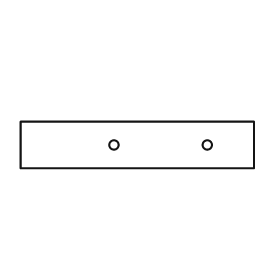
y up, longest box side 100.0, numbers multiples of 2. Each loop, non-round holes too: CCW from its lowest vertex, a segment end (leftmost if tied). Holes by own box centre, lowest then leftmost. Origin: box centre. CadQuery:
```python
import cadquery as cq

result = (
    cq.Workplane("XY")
    .moveTo(-50.0, -10.0)
    .lineTo(50.0, -10.0)
    .lineTo(50.0, 10.0)
    .lineTo(-50.0, 10.0)
    .close()
    .moveTo(-10.0, 0.0)
    .circle(2.0)
    .moveTo(30.0, 0.0)
    .circle(2.0)
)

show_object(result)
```